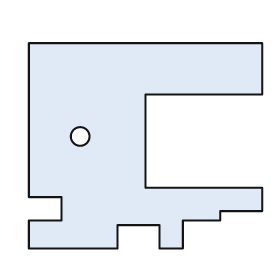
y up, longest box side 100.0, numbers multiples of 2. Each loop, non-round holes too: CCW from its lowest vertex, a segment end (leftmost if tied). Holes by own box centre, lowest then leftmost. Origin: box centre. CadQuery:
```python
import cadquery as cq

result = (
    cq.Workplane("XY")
    .moveTo(-50.0, -44.0)
    .lineTo(-12.0, -44.0)
    .lineTo(-12.0, -34.0)
    .lineTo(6.0, -34.0)
    .lineTo(6.0, -44.0)
    .lineTo(16.0, -44.0)
    .lineTo(16.0, -32.0)
    .lineTo(32.0, -32.0)
    .lineTo(32.0, -28.0)
    .lineTo(50.0, -28.0)
    .lineTo(50.0, -18.0)
    .lineTo(0.0, -18.0)
    .lineTo(0.0, 22.0)
    .lineTo(50.0, 22.0)
    .lineTo(50.0, 44.0)
    .lineTo(-50.0, 44.0)
    .lineTo(-50.0, -22.0)
    .lineTo(-36.0, -22.0)
    .lineTo(-36.0, -32.0)
    .lineTo(-50.0, -32.0)
    .close()
    .moveTo(-28.0, 4.0)
    .circle(4.0)
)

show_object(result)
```